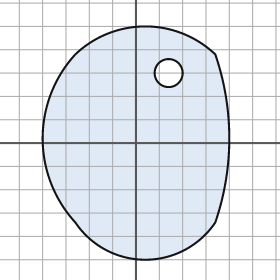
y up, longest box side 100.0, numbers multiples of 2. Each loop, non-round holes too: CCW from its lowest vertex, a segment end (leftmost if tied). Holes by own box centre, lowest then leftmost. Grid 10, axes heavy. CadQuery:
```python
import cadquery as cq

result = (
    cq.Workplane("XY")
    .moveTo(-26.0, -34.0)
    .threePointArc((4.0, -50.0), (34.0, -34.0))
    .threePointArc((40.0, 2.0), (34.0, 38.0))
    .threePointArc((4.0, 50.0), (-26.0, 38.0))
    .threePointArc((-40.0, 2.0), (-26.0, -34.0))
    .close()
    .moveTo(14.0, 30.0)
    .circle(6.0)
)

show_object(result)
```